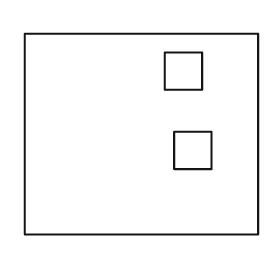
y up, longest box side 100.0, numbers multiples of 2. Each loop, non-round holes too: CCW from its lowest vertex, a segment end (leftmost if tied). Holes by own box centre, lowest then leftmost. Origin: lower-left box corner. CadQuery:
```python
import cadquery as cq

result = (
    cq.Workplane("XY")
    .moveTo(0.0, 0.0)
    .lineTo(100.0, 0.0)
    .lineTo(100.0, 86.0)
    .lineTo(0.0, 86.0)
    .close()
    .moveTo(64.0, 28.0)
    .lineTo(80.0, 28.0)
    .lineTo(80.0, 44.0)
    .lineTo(64.0, 44.0)
    .close()
    .moveTo(60.0, 62.0)
    .lineTo(76.0, 62.0)
    .lineTo(76.0, 78.0)
    .lineTo(60.0, 78.0)
    .close()
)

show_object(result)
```